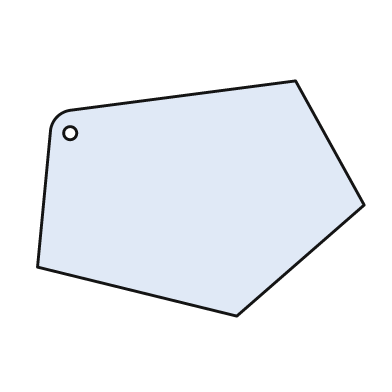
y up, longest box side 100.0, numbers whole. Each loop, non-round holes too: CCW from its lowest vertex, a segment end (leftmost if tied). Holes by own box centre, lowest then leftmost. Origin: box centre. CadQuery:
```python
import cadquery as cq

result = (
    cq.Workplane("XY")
    .moveTo(11.0, -36.0)
    .lineTo(50.0, -2.0)
    .lineTo(29.0, 36.0)
    .lineTo(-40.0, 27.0)
    .threePointArc((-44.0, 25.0), (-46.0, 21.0))
    .lineTo(-50.0, -21.0)
    .close()
    .moveTo(-40.0, 20.0)
    .circle(2.0)
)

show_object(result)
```